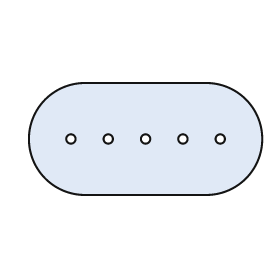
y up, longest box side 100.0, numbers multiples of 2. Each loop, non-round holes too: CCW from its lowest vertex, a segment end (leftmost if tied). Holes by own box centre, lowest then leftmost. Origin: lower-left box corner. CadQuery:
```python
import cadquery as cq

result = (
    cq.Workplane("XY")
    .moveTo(24.0, 0.0)
    .lineTo(76.0, 0.0)
    .threePointArc((100.0, 24.0), (76.0, 48.0))
    .lineTo(24.0, 48.0)
    .threePointArc((0.0, 24.0), (24.0, 0.0))
    .close()
    .moveTo(18.0, 24.0)
    .circle(2.0)
    .moveTo(34.0, 24.0)
    .circle(2.0)
    .moveTo(50.0, 24.0)
    .circle(2.0)
    .moveTo(66.0, 24.0)
    .circle(2.0)
    .moveTo(82.0, 24.0)
    .circle(2.0)
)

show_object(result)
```